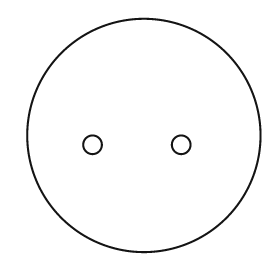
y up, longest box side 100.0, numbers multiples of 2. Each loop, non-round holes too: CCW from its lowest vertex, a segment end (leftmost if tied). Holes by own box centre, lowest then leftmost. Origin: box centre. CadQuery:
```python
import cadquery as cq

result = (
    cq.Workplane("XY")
    .moveTo(0.0, 0.0)
    .circle(50.0)
    .moveTo(-22.0, -4.0)
    .circle(4.0)
    .moveTo(16.0, -4.0)
    .circle(4.0)
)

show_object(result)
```